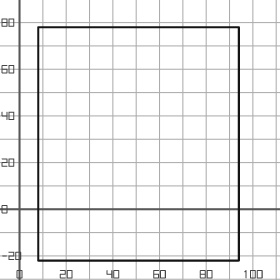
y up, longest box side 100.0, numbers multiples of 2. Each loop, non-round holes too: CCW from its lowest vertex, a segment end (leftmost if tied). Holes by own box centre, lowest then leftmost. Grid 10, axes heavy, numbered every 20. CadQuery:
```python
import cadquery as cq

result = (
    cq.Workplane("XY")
    .moveTo(8.0, -22.0)
    .lineTo(94.0, -22.0)
    .lineTo(94.0, 78.0)
    .lineTo(8.0, 78.0)
    .close()
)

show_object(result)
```